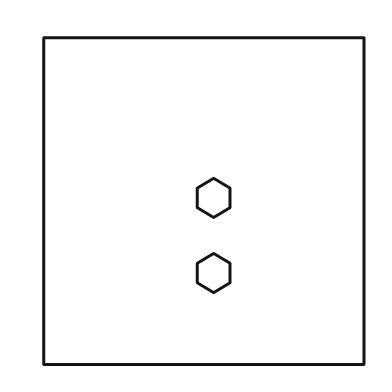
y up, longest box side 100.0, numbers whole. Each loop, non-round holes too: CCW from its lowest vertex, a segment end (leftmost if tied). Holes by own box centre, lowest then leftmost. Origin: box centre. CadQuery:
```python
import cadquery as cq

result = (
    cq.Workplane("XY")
    .moveTo(-49.0, -50.0)
    .lineTo(49.0, -50.0)
    .lineTo(49.0, 50.0)
    .lineTo(-49.0, 50.0)
    .close()
    .moveTo(3.0, -28.0)
    .lineTo(8.0, -25.0)
    .lineTo(8.0, -19.0)
    .lineTo(3.0, -16.0)
    .lineTo(-2.0, -19.0)
    .lineTo(-2.0, -25.0)
    .close()
    .moveTo(3.0, -5.0)
    .lineTo(8.0, -2.0)
    .lineTo(8.0, 4.0)
    .lineTo(3.0, 7.0)
    .lineTo(-2.0, 4.0)
    .lineTo(-2.0, -2.0)
    .close()
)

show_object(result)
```